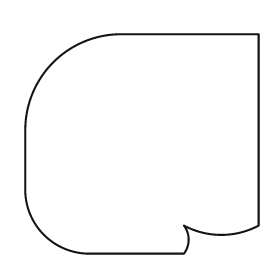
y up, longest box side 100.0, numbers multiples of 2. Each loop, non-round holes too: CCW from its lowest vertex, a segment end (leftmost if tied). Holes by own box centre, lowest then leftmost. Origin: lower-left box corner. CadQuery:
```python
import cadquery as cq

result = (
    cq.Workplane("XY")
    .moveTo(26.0, 0.0)
    .lineTo(68.0, 0.0)
    .threePointArc((70.0, 6.0), (68.0, 12.0))
    .threePointArc((84.0, 8.0), (100.0, 12.0))
    .lineTo(100.0, 94.0)
    .lineTo(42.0, 94.0)
    .threePointArc((12.0, 82.0), (0.0, 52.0))
    .lineTo(0.0, 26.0)
    .threePointArc((8.0, 8.0), (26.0, 0.0))
    .close()
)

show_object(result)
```